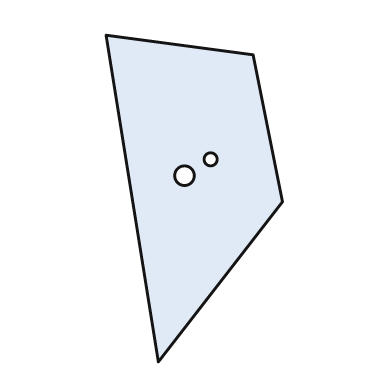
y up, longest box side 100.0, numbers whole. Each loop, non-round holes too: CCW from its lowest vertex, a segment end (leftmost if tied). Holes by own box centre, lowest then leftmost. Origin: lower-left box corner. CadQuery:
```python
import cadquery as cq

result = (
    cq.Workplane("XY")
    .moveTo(16.0, 0.0)
    .lineTo(54.0, 49.0)
    .lineTo(45.0, 94.0)
    .lineTo(0.0, 100.0)
    .close()
    .moveTo(24.0, 57.0)
    .circle(3.0)
    .moveTo(32.0, 62.0)
    .circle(2.0)
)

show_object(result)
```